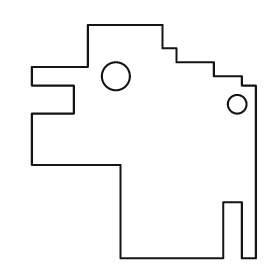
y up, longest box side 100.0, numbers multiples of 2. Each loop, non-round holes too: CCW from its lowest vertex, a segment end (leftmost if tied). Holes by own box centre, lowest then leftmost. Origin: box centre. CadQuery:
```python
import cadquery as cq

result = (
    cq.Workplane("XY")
    .moveTo(-10.0, -50.0)
    .lineTo(34.0, -50.0)
    .lineTo(34.0, -26.0)
    .lineTo(42.0, -26.0)
    .lineTo(42.0, -50.0)
    .lineTo(48.0, -50.0)
    .lineTo(48.0, 24.0)
    .lineTo(42.0, 24.0)
    .lineTo(42.0, 28.0)
    .lineTo(30.0, 28.0)
    .lineTo(30.0, 34.0)
    .lineTo(14.0, 34.0)
    .lineTo(14.0, 40.0)
    .lineTo(8.0, 40.0)
    .lineTo(8.0, 50.0)
    .lineTo(-24.0, 50.0)
    .lineTo(-24.0, 32.0)
    .lineTo(-48.0, 32.0)
    .lineTo(-48.0, 24.0)
    .lineTo(-30.0, 24.0)
    .lineTo(-30.0, 12.0)
    .lineTo(-48.0, 12.0)
    .lineTo(-48.0, -10.0)
    .lineTo(-10.0, -10.0)
    .close()
    .moveTo(40.0, 16.0)
    .circle(4.0)
    .moveTo(-12.0, 28.0)
    .circle(6.0)
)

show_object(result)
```